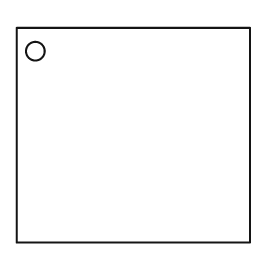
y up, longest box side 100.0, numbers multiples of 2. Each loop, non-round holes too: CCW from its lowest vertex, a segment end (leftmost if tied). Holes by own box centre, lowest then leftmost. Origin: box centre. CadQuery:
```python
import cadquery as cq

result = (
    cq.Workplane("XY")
    .moveTo(-50.0, -46.0)
    .lineTo(50.0, -46.0)
    .lineTo(50.0, 46.0)
    .lineTo(-50.0, 46.0)
    .close()
    .moveTo(-42.0, 36.0)
    .circle(4.0)
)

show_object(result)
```